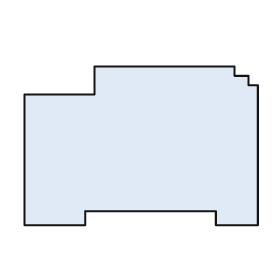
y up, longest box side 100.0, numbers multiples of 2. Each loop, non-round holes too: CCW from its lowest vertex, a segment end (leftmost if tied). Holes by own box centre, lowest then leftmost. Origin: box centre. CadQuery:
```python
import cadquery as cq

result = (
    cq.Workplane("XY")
    .moveTo(-50.0, -34.0)
    .lineTo(-24.0, -34.0)
    .lineTo(-24.0, -28.0)
    .lineTo(32.0, -28.0)
    .lineTo(32.0, -34.0)
    .lineTo(50.0, -34.0)
    .lineTo(50.0, 26.0)
    .lineTo(46.0, 26.0)
    .lineTo(46.0, 30.0)
    .lineTo(40.0, 30.0)
    .lineTo(40.0, 34.0)
    .lineTo(-20.0, 34.0)
    .lineTo(-20.0, 22.0)
    .lineTo(-50.0, 22.0)
    .close()
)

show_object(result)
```